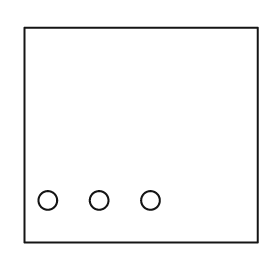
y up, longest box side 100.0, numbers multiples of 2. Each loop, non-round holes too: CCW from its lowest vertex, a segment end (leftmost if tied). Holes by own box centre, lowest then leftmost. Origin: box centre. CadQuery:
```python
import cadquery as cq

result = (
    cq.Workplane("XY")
    .moveTo(-50.0, -46.0)
    .lineTo(50.0, -46.0)
    .lineTo(50.0, 46.0)
    .lineTo(-50.0, 46.0)
    .close()
    .moveTo(-40.0, -28.0)
    .circle(4.0)
    .moveTo(-18.0, -28.0)
    .circle(4.0)
    .moveTo(4.0, -28.0)
    .circle(4.0)
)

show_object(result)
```